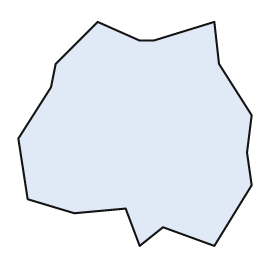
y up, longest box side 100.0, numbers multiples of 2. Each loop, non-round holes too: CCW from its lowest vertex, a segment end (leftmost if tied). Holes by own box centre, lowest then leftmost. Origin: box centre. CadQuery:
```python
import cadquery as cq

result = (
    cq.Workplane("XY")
    .moveTo(2.0, -48.0)
    .lineTo(12.0, -40.0)
    .lineTo(34.0, -48.0)
    .lineTo(50.0, -22.0)
    .lineTo(48.0, -8.0)
    .lineTo(50.0, 8.0)
    .lineTo(36.0, 30.0)
    .lineTo(34.0, 48.0)
    .lineTo(8.0, 40.0)
    .lineTo(2.0, 40.0)
    .lineTo(-16.0, 48.0)
    .lineTo(-34.0, 30.0)
    .lineTo(-36.0, 20.0)
    .lineTo(-50.0, -2.0)
    .lineTo(-46.0, -28.0)
    .lineTo(-26.0, -34.0)
    .lineTo(-4.0, -32.0)
    .close()
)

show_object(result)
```